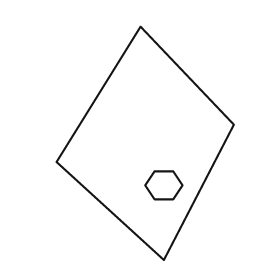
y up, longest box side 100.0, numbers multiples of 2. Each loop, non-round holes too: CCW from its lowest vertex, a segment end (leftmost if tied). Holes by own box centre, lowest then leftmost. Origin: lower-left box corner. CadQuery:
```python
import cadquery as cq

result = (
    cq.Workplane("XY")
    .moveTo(46.0, 0.0)
    .lineTo(76.0, 58.0)
    .lineTo(36.0, 100.0)
    .lineTo(0.0, 42.0)
    .close()
    .moveTo(42.0, 26.0)
    .lineTo(50.0, 26.0)
    .lineTo(54.0, 32.0)
    .lineTo(50.0, 38.0)
    .lineTo(42.0, 38.0)
    .lineTo(38.0, 32.0)
    .close()
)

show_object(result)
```